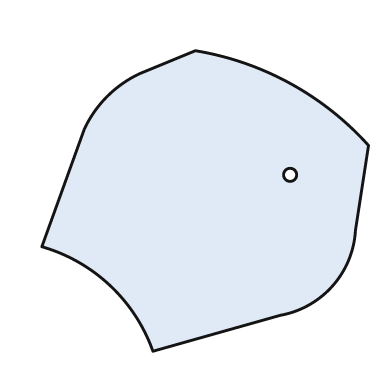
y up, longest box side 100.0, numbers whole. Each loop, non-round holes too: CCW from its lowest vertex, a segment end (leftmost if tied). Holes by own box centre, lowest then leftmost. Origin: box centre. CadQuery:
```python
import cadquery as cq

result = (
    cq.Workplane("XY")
    .moveTo(-16.0, -46.0)
    .lineTo(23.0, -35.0)
    .threePointArc((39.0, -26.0), (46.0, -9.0))
    .lineTo(50.0, 17.0)
    .threePointArc((26.0, 36.0), (-3.0, 46.0))
    .lineTo(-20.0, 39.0)
    .threePointArc((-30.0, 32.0), (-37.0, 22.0))
    .lineTo(-50.0, -14.0)
    .threePointArc((-29.0, -26.0), (-16.0, -46.0))
    .close()
    .moveTo(26.0, 8.0)
    .circle(2.0)
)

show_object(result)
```